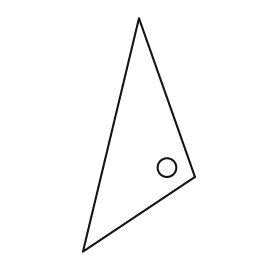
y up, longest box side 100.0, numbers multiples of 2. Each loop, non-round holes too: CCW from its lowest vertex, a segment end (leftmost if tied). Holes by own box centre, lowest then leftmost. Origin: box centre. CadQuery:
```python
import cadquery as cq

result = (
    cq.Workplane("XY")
    .moveTo(-24.0, -50.0)
    .lineTo(24.0, -18.0)
    .lineTo(0.0, 50.0)
    .close()
    .moveTo(12.0, -14.0)
    .circle(4.0)
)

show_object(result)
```